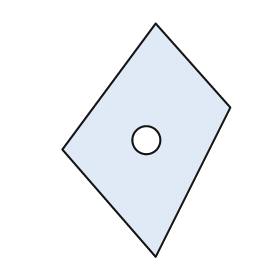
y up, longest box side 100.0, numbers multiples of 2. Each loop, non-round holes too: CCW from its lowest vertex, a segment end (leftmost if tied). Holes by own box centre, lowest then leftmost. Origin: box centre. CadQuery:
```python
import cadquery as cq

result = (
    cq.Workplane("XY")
    .moveTo(4.0, -50.0)
    .lineTo(36.0, 14.0)
    .lineTo(4.0, 50.0)
    .lineTo(-36.0, -4.0)
    .close()
    .moveTo(0.0, 0.0)
    .circle(6.0)
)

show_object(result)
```